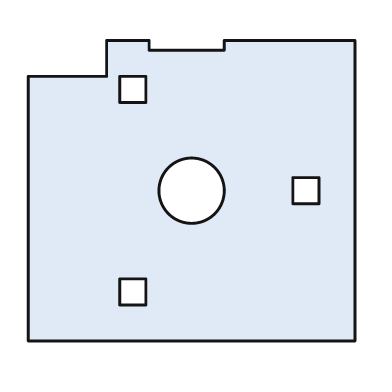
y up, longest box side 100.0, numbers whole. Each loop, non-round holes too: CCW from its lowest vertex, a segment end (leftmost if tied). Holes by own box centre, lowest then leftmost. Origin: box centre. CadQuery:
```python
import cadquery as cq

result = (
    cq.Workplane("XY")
    .moveTo(-50.0, -46.0)
    .lineTo(50.0, -46.0)
    .lineTo(50.0, 46.0)
    .lineTo(10.0, 46.0)
    .lineTo(10.0, 43.0)
    .lineTo(-13.0, 43.0)
    .lineTo(-13.0, 46.0)
    .lineTo(-26.0, 46.0)
    .lineTo(-26.0, 35.0)
    .lineTo(-50.0, 35.0)
    .close()
    .moveTo(-22.0, -35.0)
    .lineTo(-14.0, -35.0)
    .lineTo(-14.0, -27.0)
    .lineTo(-22.0, -27.0)
    .close()
    .moveTo(0.0, 0.0)
    .circle(10.0)
    .moveTo(31.0, -4.0)
    .lineTo(39.0, -4.0)
    .lineTo(39.0, 4.0)
    .lineTo(31.0, 4.0)
    .close()
    .moveTo(-22.0, 27.0)
    .lineTo(-14.0, 27.0)
    .lineTo(-14.0, 35.0)
    .lineTo(-22.0, 35.0)
    .close()
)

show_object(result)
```